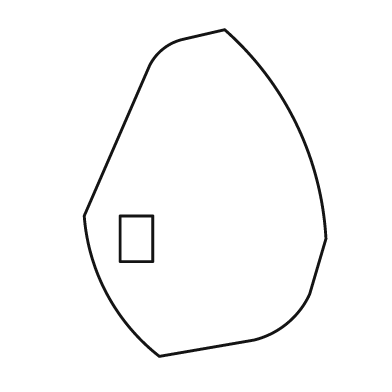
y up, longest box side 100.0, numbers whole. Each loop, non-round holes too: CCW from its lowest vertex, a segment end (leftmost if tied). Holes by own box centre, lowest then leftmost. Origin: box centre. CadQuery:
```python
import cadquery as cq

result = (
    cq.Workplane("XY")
    .moveTo(-14.0, -50.0)
    .lineTo(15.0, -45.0)
    .threePointArc((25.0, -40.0), (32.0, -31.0))
    .lineTo(37.0, -14.0)
    .threePointArc((28.0, 21.0), (6.0, 50.0))
    .lineTo(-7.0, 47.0)
    .threePointArc((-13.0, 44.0), (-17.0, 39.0))
    .lineTo(-37.0, -7.0)
    .threePointArc((-30.0, -31.0), (-14.0, -50.0))
    .close()
    .moveTo(-26.0, -21.0)
    .lineTo(-16.0, -21.0)
    .lineTo(-16.0, -7.0)
    .lineTo(-26.0, -7.0)
    .close()
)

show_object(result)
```